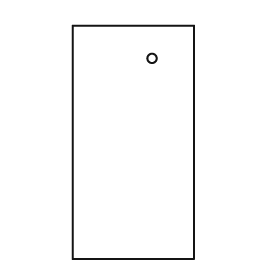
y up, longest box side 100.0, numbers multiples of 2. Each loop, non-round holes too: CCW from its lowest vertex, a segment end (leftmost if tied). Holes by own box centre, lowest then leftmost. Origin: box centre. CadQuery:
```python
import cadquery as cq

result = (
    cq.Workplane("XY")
    .moveTo(-26.0, -50.0)
    .lineTo(26.0, -50.0)
    .lineTo(26.0, 50.0)
    .lineTo(-26.0, 50.0)
    .close()
    .moveTo(8.0, 36.0)
    .circle(2.0)
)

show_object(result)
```